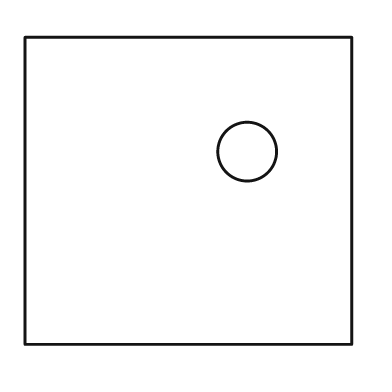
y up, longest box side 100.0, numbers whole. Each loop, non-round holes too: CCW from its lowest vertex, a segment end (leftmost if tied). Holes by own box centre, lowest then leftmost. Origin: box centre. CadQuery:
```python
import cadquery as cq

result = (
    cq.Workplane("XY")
    .moveTo(-50.0, -47.0)
    .lineTo(50.0, -47.0)
    .lineTo(50.0, 47.0)
    .lineTo(-50.0, 47.0)
    .close()
    .moveTo(18.0, 12.0)
    .circle(9.0)
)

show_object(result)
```